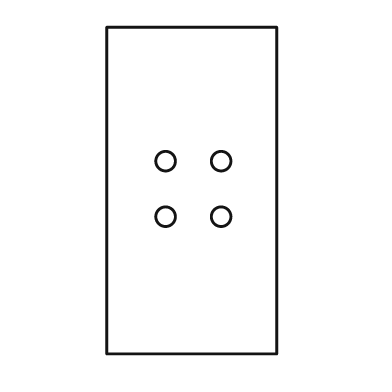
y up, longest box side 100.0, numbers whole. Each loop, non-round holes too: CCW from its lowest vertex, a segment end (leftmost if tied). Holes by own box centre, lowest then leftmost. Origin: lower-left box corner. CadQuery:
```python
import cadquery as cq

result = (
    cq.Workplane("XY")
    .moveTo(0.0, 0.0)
    .lineTo(52.0, 0.0)
    .lineTo(52.0, 100.0)
    .lineTo(0.0, 100.0)
    .close()
    .moveTo(18.0, 42.0)
    .circle(3.0)
    .moveTo(35.0, 42.0)
    .circle(3.0)
    .moveTo(18.0, 59.0)
    .circle(3.0)
    .moveTo(35.0, 59.0)
    .circle(3.0)
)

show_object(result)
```